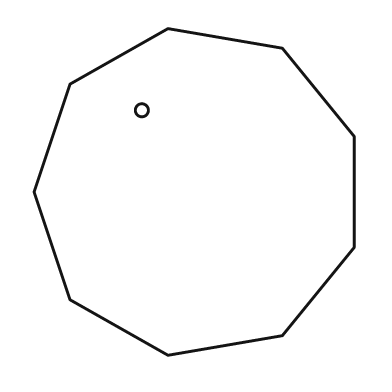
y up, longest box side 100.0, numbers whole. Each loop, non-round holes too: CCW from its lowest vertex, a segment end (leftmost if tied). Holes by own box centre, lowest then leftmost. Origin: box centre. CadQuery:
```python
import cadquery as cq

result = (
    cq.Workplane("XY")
    .moveTo(-8.0, -50.0)
    .lineTo(27.0, -44.0)
    .lineTo(49.0, -17.0)
    .lineTo(49.0, 17.0)
    .lineTo(27.0, 44.0)
    .lineTo(-8.0, 50.0)
    .lineTo(-38.0, 33.0)
    .lineTo(-49.0, 0.0)
    .lineTo(-38.0, -33.0)
    .close()
    .moveTo(-16.0, 25.0)
    .circle(2.0)
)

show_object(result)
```